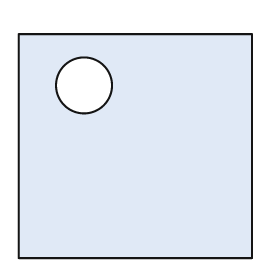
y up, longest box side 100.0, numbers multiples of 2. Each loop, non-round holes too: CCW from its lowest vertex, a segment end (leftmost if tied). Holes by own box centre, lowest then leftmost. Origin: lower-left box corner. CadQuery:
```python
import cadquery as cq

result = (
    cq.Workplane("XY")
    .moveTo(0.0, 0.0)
    .lineTo(100.0, 0.0)
    .lineTo(100.0, 96.0)
    .lineTo(0.0, 96.0)
    .close()
    .moveTo(28.0, 74.0)
    .circle(12.0)
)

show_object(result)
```